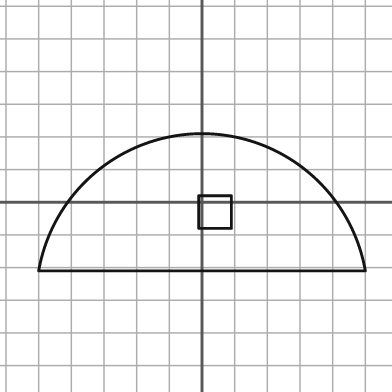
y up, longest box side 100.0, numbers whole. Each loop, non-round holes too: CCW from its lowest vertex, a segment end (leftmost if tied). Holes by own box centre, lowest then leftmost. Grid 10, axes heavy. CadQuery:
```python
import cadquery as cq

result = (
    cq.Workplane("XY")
    .moveTo(-50.0, -21.0)
    .lineTo(50.0, -21.0)
    .threePointArc((0.0, 21.0), (-50.0, -21.0))
    .close()
    .moveTo(-1.0, -8.0)
    .lineTo(9.0, -8.0)
    .lineTo(9.0, 2.0)
    .lineTo(-1.0, 2.0)
    .close()
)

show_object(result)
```